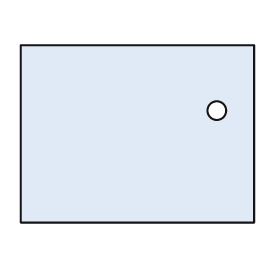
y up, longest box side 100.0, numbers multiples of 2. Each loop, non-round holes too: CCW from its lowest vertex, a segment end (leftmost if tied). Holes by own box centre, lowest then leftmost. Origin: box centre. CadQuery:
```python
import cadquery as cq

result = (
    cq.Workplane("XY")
    .moveTo(-50.0, -38.0)
    .lineTo(50.0, -38.0)
    .lineTo(50.0, 38.0)
    .lineTo(-50.0, 38.0)
    .close()
    .moveTo(34.0, 10.0)
    .circle(4.0)
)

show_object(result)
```